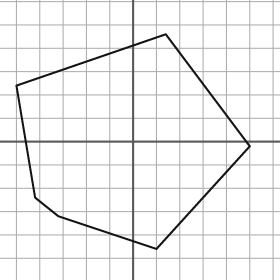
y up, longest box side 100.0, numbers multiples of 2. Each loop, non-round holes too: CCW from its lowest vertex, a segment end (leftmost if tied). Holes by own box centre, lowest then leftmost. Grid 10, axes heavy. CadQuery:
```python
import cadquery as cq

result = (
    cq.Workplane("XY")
    .moveTo(10.0, -46.0)
    .lineTo(50.0, -2.0)
    .lineTo(14.0, 46.0)
    .lineTo(-50.0, 24.0)
    .lineTo(-42.0, -24.0)
    .lineTo(-32.0, -32.0)
    .close()
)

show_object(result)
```